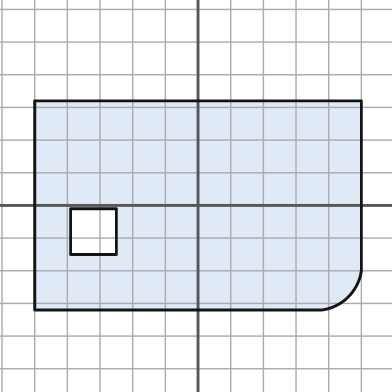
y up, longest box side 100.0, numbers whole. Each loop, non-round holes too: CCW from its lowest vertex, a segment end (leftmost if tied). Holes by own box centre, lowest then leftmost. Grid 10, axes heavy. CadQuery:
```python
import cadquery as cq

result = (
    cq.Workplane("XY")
    .moveTo(-50.0, -32.0)
    .lineTo(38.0, -32.0)
    .threePointArc((46.0, -28.0), (50.0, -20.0))
    .lineTo(50.0, 32.0)
    .lineTo(-50.0, 32.0)
    .close()
    .moveTo(-39.0, -15.0)
    .lineTo(-25.0, -15.0)
    .lineTo(-25.0, -1.0)
    .lineTo(-39.0, -1.0)
    .close()
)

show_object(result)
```